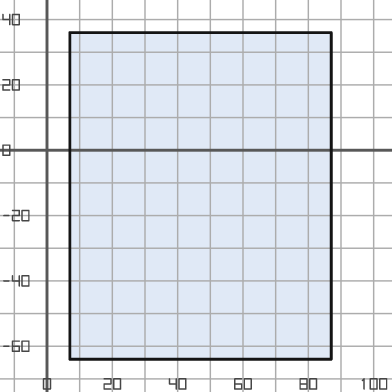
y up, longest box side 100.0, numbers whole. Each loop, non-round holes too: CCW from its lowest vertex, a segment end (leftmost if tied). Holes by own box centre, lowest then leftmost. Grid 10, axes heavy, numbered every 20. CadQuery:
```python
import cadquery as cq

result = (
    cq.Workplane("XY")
    .moveTo(7.0, -64.0)
    .lineTo(87.0, -64.0)
    .lineTo(87.0, 36.0)
    .lineTo(7.0, 36.0)
    .close()
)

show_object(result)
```